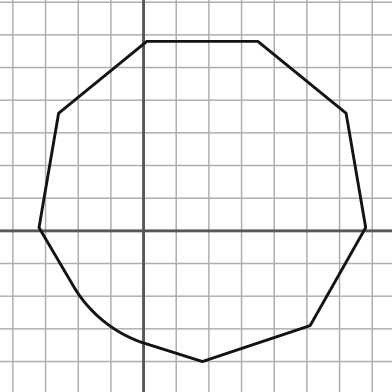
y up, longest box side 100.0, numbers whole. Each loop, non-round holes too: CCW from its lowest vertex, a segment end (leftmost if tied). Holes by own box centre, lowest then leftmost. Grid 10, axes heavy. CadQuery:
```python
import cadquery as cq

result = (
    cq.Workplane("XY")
    .moveTo(18.0, -40.0)
    .lineTo(51.0, -29.0)
    .lineTo(68.0, 1.0)
    .lineTo(62.0, 36.0)
    .lineTo(35.0, 58.0)
    .lineTo(1.0, 58.0)
    .lineTo(-26.0, 36.0)
    .lineTo(-32.0, 1.0)
    .lineTo(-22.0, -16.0)
    .threePointArc((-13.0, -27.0), (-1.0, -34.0))
    .close()
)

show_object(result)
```